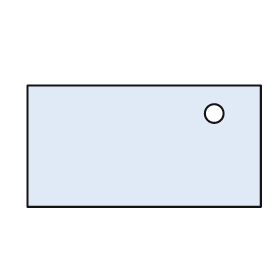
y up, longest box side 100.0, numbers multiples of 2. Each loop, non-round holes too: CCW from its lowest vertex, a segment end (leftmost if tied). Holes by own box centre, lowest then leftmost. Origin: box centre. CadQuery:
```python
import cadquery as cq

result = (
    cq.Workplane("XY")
    .moveTo(-50.0, -26.0)
    .lineTo(50.0, -26.0)
    .lineTo(50.0, 26.0)
    .lineTo(-50.0, 26.0)
    .close()
    .moveTo(30.0, 14.0)
    .circle(4.0)
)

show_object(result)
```